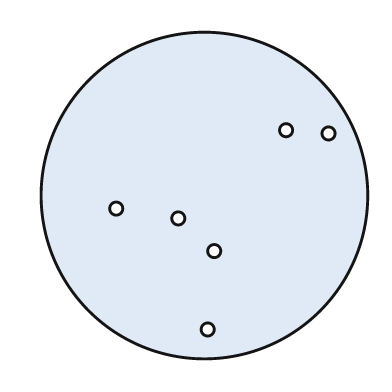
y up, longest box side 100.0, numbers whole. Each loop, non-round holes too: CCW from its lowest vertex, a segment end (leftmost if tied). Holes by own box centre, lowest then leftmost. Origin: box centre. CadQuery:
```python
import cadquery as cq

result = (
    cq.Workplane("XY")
    .moveTo(0.0, 0.0)
    .circle(50.0)
    .moveTo(1.0, -41.0)
    .circle(2.0)
    .moveTo(3.0, -17.0)
    .circle(2.0)
    .moveTo(-8.0, -7.0)
    .circle(2.0)
    .moveTo(-27.0, -4.0)
    .circle(2.0)
    .moveTo(38.0, 19.0)
    .circle(2.0)
    .moveTo(25.0, 20.0)
    .circle(2.0)
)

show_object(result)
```